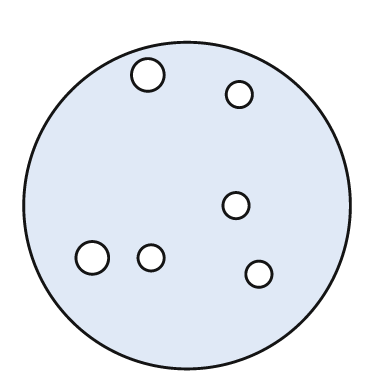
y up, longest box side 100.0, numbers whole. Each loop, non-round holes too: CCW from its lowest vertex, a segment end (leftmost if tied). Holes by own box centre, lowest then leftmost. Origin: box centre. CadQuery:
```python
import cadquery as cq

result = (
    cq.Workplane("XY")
    .moveTo(0.0, 0.0)
    .circle(50.0)
    .moveTo(22.0, -21.0)
    .circle(4.0)
    .moveTo(-29.0, -16.0)
    .circle(5.0)
    .moveTo(-11.0, -16.0)
    .circle(4.0)
    .moveTo(15.0, 0.0)
    .circle(4.0)
    .moveTo(16.0, 34.0)
    .circle(4.0)
    .moveTo(-12.0, 40.0)
    .circle(5.0)
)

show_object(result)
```